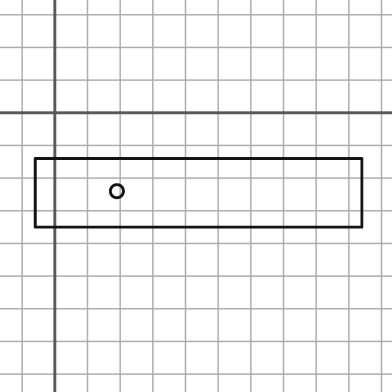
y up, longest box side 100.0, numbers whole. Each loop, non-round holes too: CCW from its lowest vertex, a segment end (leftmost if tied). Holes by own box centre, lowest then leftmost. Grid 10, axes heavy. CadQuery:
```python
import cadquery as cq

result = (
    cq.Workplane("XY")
    .moveTo(-6.0, -35.0)
    .lineTo(94.0, -35.0)
    .lineTo(94.0, -14.0)
    .lineTo(-6.0, -14.0)
    .close()
    .moveTo(19.0, -24.0)
    .circle(2.0)
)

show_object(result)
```